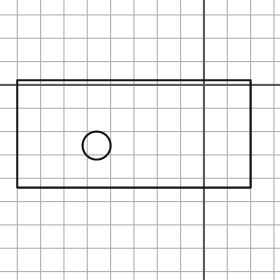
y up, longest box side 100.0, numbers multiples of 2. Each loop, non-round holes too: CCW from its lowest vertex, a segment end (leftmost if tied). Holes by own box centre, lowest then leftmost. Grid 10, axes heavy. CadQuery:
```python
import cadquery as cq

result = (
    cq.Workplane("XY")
    .moveTo(-80.0, -44.0)
    .lineTo(20.0, -44.0)
    .lineTo(20.0, 2.0)
    .lineTo(-80.0, 2.0)
    .close()
    .moveTo(-46.0, -26.0)
    .circle(6.0)
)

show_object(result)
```